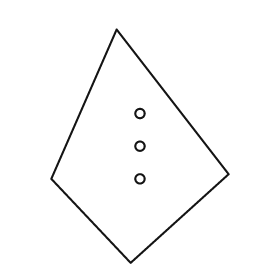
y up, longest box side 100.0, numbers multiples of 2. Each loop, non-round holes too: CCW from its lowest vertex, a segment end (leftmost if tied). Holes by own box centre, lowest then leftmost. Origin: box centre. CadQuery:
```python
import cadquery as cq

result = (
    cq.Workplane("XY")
    .moveTo(-4.0, -50.0)
    .lineTo(38.0, -12.0)
    .lineTo(-10.0, 50.0)
    .lineTo(-38.0, -14.0)
    .close()
    .moveTo(0.0, -14.0)
    .circle(2.0)
    .moveTo(0.0, 0.0)
    .circle(2.0)
    .moveTo(0.0, 14.0)
    .circle(2.0)
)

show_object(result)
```